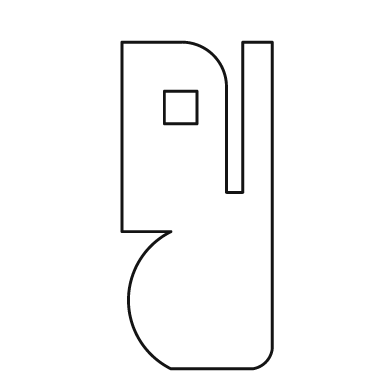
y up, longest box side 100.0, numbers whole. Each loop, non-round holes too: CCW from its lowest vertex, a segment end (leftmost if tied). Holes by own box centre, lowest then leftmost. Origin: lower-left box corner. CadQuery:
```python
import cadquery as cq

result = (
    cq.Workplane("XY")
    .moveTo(15.0, 0.0)
    .lineTo(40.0, 0.0)
    .threePointArc((44.0, 2.0), (46.0, 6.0))
    .lineTo(46.0, 100.0)
    .lineTo(37.0, 100.0)
    .lineTo(37.0, 54.0)
    .lineTo(32.0, 54.0)
    .lineTo(32.0, 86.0)
    .threePointArc((28.0, 96.0), (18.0, 100.0))
    .lineTo(0.0, 100.0)
    .lineTo(0.0, 42.0)
    .lineTo(15.0, 42.0)
    .threePointArc((2.0, 21.0), (15.0, 0.0))
    .close()
    .moveTo(13.0, 75.0)
    .lineTo(23.0, 75.0)
    .lineTo(23.0, 85.0)
    .lineTo(13.0, 85.0)
    .close()
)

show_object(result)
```